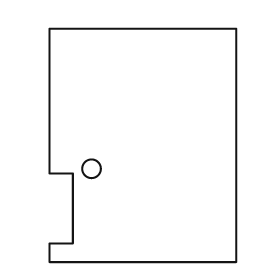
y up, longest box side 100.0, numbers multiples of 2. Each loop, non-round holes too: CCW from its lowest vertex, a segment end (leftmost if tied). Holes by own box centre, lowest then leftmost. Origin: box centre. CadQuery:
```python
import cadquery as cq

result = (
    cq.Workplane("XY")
    .moveTo(-40.0, -50.0)
    .lineTo(40.0, -50.0)
    .lineTo(40.0, 50.0)
    .lineTo(-40.0, 50.0)
    .lineTo(-40.0, -12.0)
    .lineTo(-30.0, -12.0)
    .lineTo(-30.0, -42.0)
    .lineTo(-40.0, -42.0)
    .close()
    .moveTo(-22.0, -10.0)
    .circle(4.0)
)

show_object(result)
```